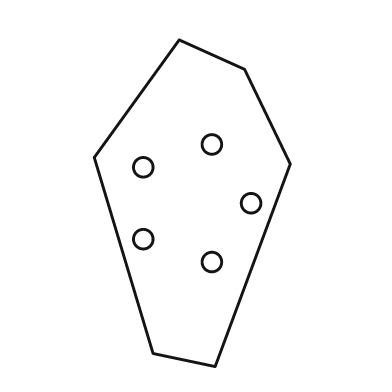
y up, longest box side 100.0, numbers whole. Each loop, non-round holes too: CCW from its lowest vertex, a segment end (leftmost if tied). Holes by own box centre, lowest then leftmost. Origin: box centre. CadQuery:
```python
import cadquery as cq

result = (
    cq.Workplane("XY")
    .moveTo(7.0, -50.0)
    .lineTo(30.0, 12.0)
    .lineTo(16.0, 41.0)
    .lineTo(-4.0, 50.0)
    .lineTo(-30.0, 14.0)
    .lineTo(-12.0, -46.0)
    .close()
    .moveTo(6.0, -18.0)
    .circle(3.0)
    .moveTo(-15.0, -11.0)
    .circle(3.0)
    .moveTo(18.0, 0.0)
    .circle(3.0)
    .moveTo(-15.0, 11.0)
    .circle(3.0)
    .moveTo(6.0, 18.0)
    .circle(3.0)
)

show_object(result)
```